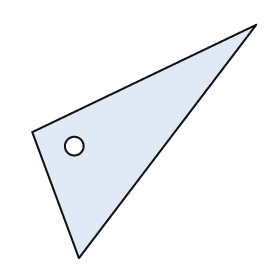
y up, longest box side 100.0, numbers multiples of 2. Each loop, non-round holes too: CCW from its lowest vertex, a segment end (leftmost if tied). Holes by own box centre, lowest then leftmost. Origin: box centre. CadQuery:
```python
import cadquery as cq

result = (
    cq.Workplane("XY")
    .moveTo(-28.0, -50.0)
    .lineTo(48.0, 50.0)
    .lineTo(-48.0, 4.0)
    .close()
    .moveTo(-30.0, -2.0)
    .circle(4.0)
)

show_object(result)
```